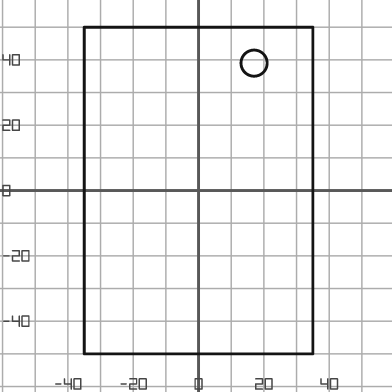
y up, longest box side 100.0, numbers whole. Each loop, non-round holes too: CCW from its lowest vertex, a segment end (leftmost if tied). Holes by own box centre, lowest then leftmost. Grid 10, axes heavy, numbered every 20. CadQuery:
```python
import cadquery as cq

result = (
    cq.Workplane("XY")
    .moveTo(-35.0, -50.0)
    .lineTo(35.0, -50.0)
    .lineTo(35.0, 50.0)
    .lineTo(-35.0, 50.0)
    .close()
    .moveTo(17.0, 39.0)
    .circle(4.0)
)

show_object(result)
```